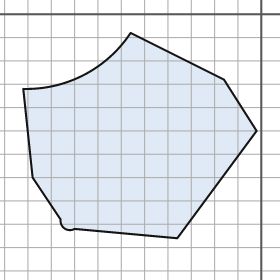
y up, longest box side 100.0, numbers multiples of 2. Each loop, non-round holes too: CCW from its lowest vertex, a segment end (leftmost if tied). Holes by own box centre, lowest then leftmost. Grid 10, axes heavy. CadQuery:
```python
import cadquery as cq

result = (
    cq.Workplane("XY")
    .moveTo(-36.0, -96.0)
    .lineTo(-2.0, -50.0)
    .lineTo(-16.0, -28.0)
    .lineTo(-56.0, -8.0)
    .threePointArc((-76.0, -26.0), (-102.0, -32.0))
    .lineTo(-98.0, -70.0)
    .lineTo(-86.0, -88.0)
    .threePointArc((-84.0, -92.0), (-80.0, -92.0))
    .close()
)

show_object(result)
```